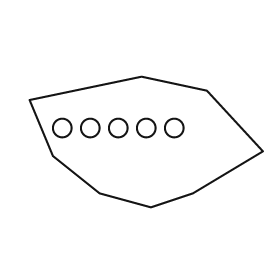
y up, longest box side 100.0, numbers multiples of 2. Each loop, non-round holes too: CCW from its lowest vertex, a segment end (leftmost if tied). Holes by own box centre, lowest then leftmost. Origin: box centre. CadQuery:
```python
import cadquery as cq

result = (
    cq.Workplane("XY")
    .moveTo(2.0, -28.0)
    .lineTo(20.0, -22.0)
    .lineTo(50.0, -4.0)
    .lineTo(26.0, 22.0)
    .lineTo(-2.0, 28.0)
    .lineTo(-50.0, 18.0)
    .lineTo(-40.0, -6.0)
    .lineTo(-20.0, -22.0)
    .close()
    .moveTo(-36.0, 6.0)
    .circle(4.0)
    .moveTo(-24.0, 6.0)
    .circle(4.0)
    .moveTo(-12.0, 6.0)
    .circle(4.0)
    .moveTo(0.0, 6.0)
    .circle(4.0)
    .moveTo(12.0, 6.0)
    .circle(4.0)
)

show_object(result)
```